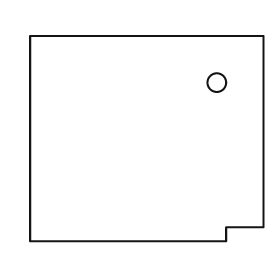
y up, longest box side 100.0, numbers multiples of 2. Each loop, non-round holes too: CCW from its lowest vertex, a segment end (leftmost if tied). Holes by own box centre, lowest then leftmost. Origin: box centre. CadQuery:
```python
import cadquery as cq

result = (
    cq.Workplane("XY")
    .moveTo(-50.0, -44.0)
    .lineTo(34.0, -44.0)
    .lineTo(34.0, -38.0)
    .lineTo(50.0, -38.0)
    .lineTo(50.0, 44.0)
    .lineTo(-50.0, 44.0)
    .close()
    .moveTo(30.0, 24.0)
    .circle(4.0)
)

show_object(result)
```